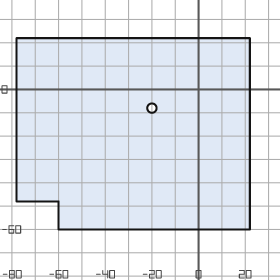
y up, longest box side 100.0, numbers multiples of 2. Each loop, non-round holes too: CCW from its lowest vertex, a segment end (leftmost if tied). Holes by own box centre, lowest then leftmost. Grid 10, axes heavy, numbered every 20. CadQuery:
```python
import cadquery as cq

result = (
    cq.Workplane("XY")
    .moveTo(-60.0, -60.0)
    .lineTo(22.0, -60.0)
    .lineTo(22.0, 22.0)
    .lineTo(-78.0, 22.0)
    .lineTo(-78.0, -48.0)
    .lineTo(-60.0, -48.0)
    .close()
    .moveTo(-20.0, -8.0)
    .circle(2.0)
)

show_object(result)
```